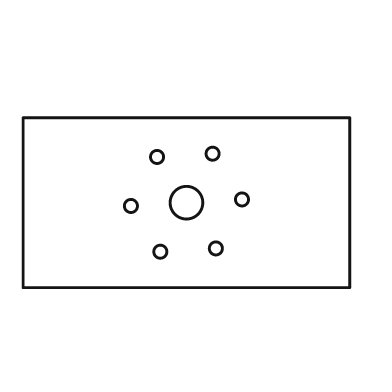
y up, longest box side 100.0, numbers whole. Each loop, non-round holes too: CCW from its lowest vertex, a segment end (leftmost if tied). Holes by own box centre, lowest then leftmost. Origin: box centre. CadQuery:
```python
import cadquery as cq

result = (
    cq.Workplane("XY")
    .moveTo(-50.0, -26.0)
    .lineTo(50.0, -26.0)
    .lineTo(50.0, 26.0)
    .lineTo(-50.0, 26.0)
    .close()
    .moveTo(-8.0, -15.0)
    .circle(2.0)
    .moveTo(9.0, -14.0)
    .circle(2.0)
    .moveTo(-17.0, -1.0)
    .circle(2.0)
    .moveTo(0.0, 0.0)
    .circle(5.0)
    .moveTo(17.0, 1.0)
    .circle(2.0)
    .moveTo(-9.0, 14.0)
    .circle(2.0)
    .moveTo(8.0, 15.0)
    .circle(2.0)
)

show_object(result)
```